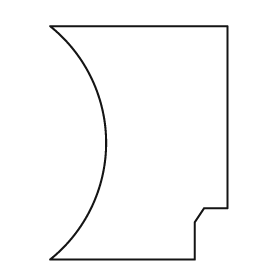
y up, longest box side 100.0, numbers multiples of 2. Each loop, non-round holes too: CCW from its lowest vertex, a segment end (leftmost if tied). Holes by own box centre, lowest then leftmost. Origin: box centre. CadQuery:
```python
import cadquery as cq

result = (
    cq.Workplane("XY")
    .moveTo(-38.0, -50.0)
    .lineTo(24.0, -50.0)
    .lineTo(24.0, -34.0)
    .lineTo(28.0, -28.0)
    .lineTo(38.0, -28.0)
    .lineTo(38.0, 50.0)
    .lineTo(-38.0, 50.0)
    .threePointArc((-14.0, 0.0), (-38.0, -50.0))
    .close()
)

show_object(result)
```